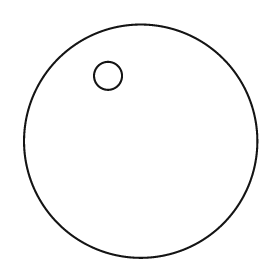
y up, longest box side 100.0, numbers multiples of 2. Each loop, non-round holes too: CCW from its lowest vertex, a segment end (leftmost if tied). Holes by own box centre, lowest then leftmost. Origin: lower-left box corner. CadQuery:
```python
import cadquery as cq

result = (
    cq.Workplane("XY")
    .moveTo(50.0, 50.0)
    .circle(50.0)
    .moveTo(36.0, 78.0)
    .circle(6.0)
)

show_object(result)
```